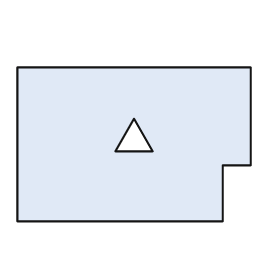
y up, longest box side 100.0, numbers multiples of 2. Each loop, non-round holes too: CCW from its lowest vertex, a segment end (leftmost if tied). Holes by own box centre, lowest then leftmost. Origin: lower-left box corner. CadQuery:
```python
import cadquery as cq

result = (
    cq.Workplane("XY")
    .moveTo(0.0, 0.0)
    .lineTo(88.0, 0.0)
    .lineTo(88.0, 24.0)
    .lineTo(100.0, 24.0)
    .lineTo(100.0, 66.0)
    .lineTo(0.0, 66.0)
    .close()
    .moveTo(42.0, 30.0)
    .lineTo(58.0, 30.0)
    .lineTo(50.0, 44.0)
    .close()
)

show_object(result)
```